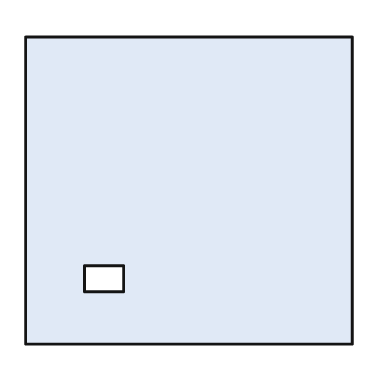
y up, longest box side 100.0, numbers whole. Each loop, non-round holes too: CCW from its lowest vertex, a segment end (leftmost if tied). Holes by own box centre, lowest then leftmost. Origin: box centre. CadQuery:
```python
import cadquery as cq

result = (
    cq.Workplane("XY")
    .moveTo(-50.0, -47.0)
    .lineTo(50.0, -47.0)
    .lineTo(50.0, 47.0)
    .lineTo(-50.0, 47.0)
    .close()
    .moveTo(-32.0, -31.0)
    .lineTo(-20.0, -31.0)
    .lineTo(-20.0, -23.0)
    .lineTo(-32.0, -23.0)
    .close()
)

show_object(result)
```